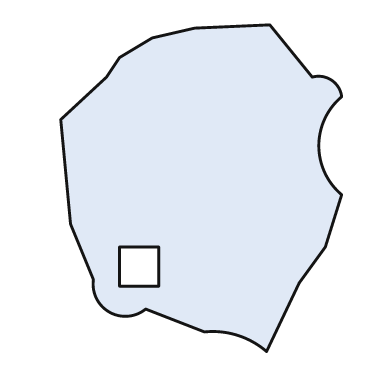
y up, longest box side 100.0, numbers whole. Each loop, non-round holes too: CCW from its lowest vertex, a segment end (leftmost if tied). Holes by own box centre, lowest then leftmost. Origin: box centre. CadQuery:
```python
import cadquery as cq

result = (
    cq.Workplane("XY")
    .moveTo(20.0, -50.0)
    .lineTo(30.0, -29.0)
    .lineTo(38.0, -18.0)
    .lineTo(43.0, -2.0)
    .threePointArc((36.0, 13.0), (43.0, 28.0))
    .threePointArc((40.0, 33.0), (34.0, 34.0))
    .lineTo(21.0, 50.0)
    .lineTo(-2.0, 49.0)
    .lineTo(-15.0, 46.0)
    .lineTo(-25.0, 40.0)
    .lineTo(-29.0, 34.0)
    .lineTo(-43.0, 21.0)
    .lineTo(-40.0, -11.0)
    .lineTo(-33.0, -28.0)
    .threePointArc((-28.0, -38.0), (-17.0, -37.0))
    .lineTo(1.0, -44.0)
    .threePointArc((11.0, -45.0), (20.0, -50.0))
    .close()
    .moveTo(-25.0, -30.0)
    .lineTo(-13.0, -30.0)
    .lineTo(-13.0, -18.0)
    .lineTo(-25.0, -18.0)
    .close()
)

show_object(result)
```